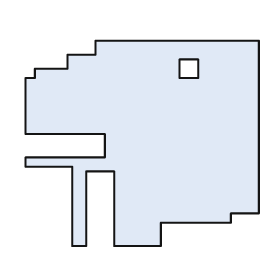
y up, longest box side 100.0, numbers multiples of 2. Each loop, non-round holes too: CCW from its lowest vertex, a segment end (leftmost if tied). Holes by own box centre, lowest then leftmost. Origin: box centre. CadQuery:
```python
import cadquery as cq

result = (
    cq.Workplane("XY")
    .moveTo(-30.0, -44.0)
    .lineTo(-24.0, -44.0)
    .lineTo(-24.0, -12.0)
    .lineTo(-12.0, -12.0)
    .lineTo(-12.0, -44.0)
    .lineTo(8.0, -44.0)
    .lineTo(8.0, -34.0)
    .lineTo(38.0, -34.0)
    .lineTo(38.0, -30.0)
    .lineTo(50.0, -30.0)
    .lineTo(50.0, 44.0)
    .lineTo(-20.0, 44.0)
    .lineTo(-20.0, 38.0)
    .lineTo(-32.0, 38.0)
    .lineTo(-32.0, 32.0)
    .lineTo(-46.0, 32.0)
    .lineTo(-46.0, 28.0)
    .lineTo(-50.0, 28.0)
    .lineTo(-50.0, 4.0)
    .lineTo(-16.0, 4.0)
    .lineTo(-16.0, -6.0)
    .lineTo(-50.0, -6.0)
    .lineTo(-50.0, -10.0)
    .lineTo(-30.0, -10.0)
    .close()
    .moveTo(16.0, 28.0)
    .lineTo(24.0, 28.0)
    .lineTo(24.0, 36.0)
    .lineTo(16.0, 36.0)
    .close()
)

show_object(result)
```